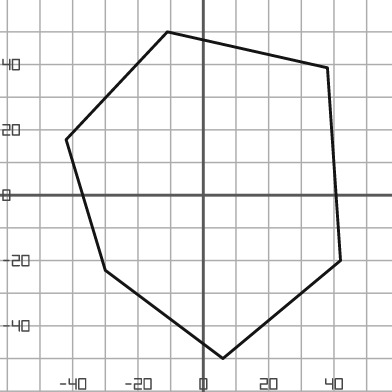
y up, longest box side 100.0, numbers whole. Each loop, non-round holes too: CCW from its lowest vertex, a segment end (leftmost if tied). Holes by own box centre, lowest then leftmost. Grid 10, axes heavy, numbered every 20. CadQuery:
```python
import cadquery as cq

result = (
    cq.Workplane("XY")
    .moveTo(6.0, -50.0)
    .lineTo(42.0, -20.0)
    .lineTo(38.0, 39.0)
    .lineTo(-11.0, 50.0)
    .lineTo(-42.0, 17.0)
    .lineTo(-30.0, -23.0)
    .close()
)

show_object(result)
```